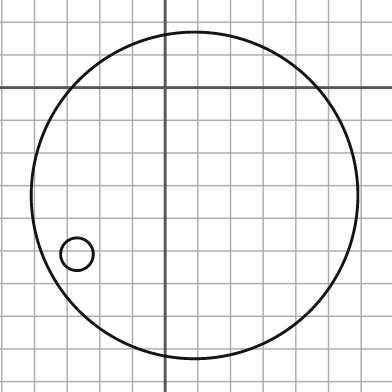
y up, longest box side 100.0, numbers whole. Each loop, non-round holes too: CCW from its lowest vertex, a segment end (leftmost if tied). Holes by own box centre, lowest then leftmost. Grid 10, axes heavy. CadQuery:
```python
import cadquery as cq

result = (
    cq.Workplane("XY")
    .moveTo(9.0, -33.0)
    .circle(50.0)
    .moveTo(-27.0, -51.0)
    .circle(5.0)
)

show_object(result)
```